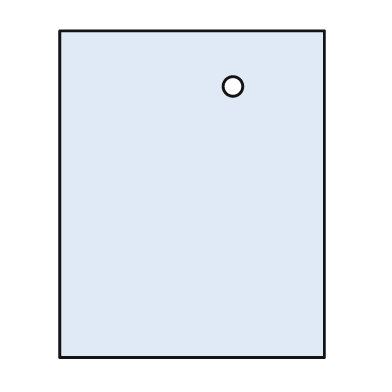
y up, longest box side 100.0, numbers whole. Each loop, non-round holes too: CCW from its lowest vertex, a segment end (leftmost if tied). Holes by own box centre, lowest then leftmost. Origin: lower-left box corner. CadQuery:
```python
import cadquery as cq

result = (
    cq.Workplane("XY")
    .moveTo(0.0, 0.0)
    .lineTo(81.0, 0.0)
    .lineTo(81.0, 100.0)
    .lineTo(0.0, 100.0)
    .close()
    .moveTo(53.0, 83.0)
    .circle(3.0)
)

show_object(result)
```